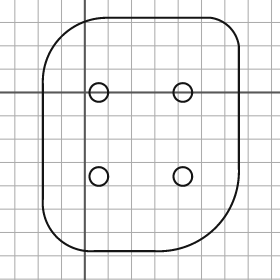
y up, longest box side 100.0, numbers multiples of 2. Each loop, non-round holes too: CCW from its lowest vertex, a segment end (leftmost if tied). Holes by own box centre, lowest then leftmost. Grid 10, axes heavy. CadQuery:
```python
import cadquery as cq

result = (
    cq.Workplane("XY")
    .moveTo(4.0, -68.0)
    .lineTo(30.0, -68.0)
    .threePointArc((56.0, -58.0), (66.0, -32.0))
    .lineTo(66.0, 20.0)
    .threePointArc((62.0, 28.0), (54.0, 32.0))
    .lineTo(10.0, 32.0)
    .threePointArc((-10.0, 24.0), (-18.0, 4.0))
    .lineTo(-18.0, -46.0)
    .threePointArc((-12.0, -62.0), (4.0, -68.0))
    .close()
    .moveTo(6.0, -36.0)
    .circle(4.0)
    .moveTo(42.0, -36.0)
    .circle(4.0)
    .moveTo(6.0, 0.0)
    .circle(4.0)
    .moveTo(42.0, 0.0)
    .circle(4.0)
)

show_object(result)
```